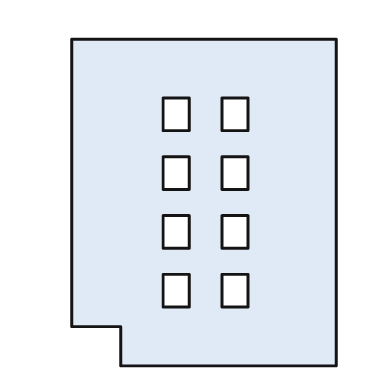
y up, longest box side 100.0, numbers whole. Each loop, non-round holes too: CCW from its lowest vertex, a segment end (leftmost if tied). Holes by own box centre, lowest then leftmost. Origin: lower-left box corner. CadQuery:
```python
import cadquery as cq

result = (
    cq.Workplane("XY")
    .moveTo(15.0, 0.0)
    .lineTo(81.0, 0.0)
    .lineTo(81.0, 100.0)
    .lineTo(0.0, 100.0)
    .lineTo(0.0, 12.0)
    .lineTo(15.0, 12.0)
    .close()
    .moveTo(28.0, 18.0)
    .lineTo(36.0, 18.0)
    .lineTo(36.0, 28.0)
    .lineTo(28.0, 28.0)
    .close()
    .moveTo(46.0, 18.0)
    .lineTo(54.0, 18.0)
    .lineTo(54.0, 28.0)
    .lineTo(46.0, 28.0)
    .close()
    .moveTo(28.0, 36.0)
    .lineTo(36.0, 36.0)
    .lineTo(36.0, 46.0)
    .lineTo(28.0, 46.0)
    .close()
    .moveTo(46.0, 36.0)
    .lineTo(54.0, 36.0)
    .lineTo(54.0, 46.0)
    .lineTo(46.0, 46.0)
    .close()
    .moveTo(28.0, 54.0)
    .lineTo(36.0, 54.0)
    .lineTo(36.0, 64.0)
    .lineTo(28.0, 64.0)
    .close()
    .moveTo(46.0, 54.0)
    .lineTo(54.0, 54.0)
    .lineTo(54.0, 64.0)
    .lineTo(46.0, 64.0)
    .close()
    .moveTo(28.0, 72.0)
    .lineTo(36.0, 72.0)
    .lineTo(36.0, 82.0)
    .lineTo(28.0, 82.0)
    .close()
    .moveTo(46.0, 72.0)
    .lineTo(54.0, 72.0)
    .lineTo(54.0, 82.0)
    .lineTo(46.0, 82.0)
    .close()
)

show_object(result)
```